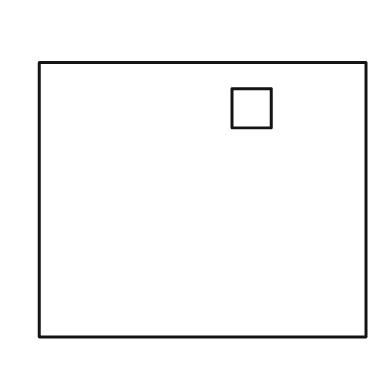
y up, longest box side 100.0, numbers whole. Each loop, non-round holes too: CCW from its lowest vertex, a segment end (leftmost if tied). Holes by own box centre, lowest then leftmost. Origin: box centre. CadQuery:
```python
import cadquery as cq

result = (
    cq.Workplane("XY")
    .moveTo(-50.0, -42.0)
    .lineTo(50.0, -42.0)
    .lineTo(50.0, 42.0)
    .lineTo(-50.0, 42.0)
    .close()
    .moveTo(9.0, 22.0)
    .lineTo(21.0, 22.0)
    .lineTo(21.0, 34.0)
    .lineTo(9.0, 34.0)
    .close()
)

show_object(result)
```